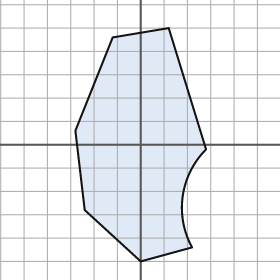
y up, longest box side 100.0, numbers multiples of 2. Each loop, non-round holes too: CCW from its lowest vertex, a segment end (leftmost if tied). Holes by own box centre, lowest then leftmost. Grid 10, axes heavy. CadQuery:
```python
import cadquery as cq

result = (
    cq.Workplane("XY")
    .moveTo(0.0, -50.0)
    .lineTo(22.0, -44.0)
    .threePointArc((18.0, -22.0), (28.0, -2.0))
    .lineTo(12.0, 50.0)
    .lineTo(-12.0, 46.0)
    .lineTo(-28.0, 6.0)
    .lineTo(-24.0, -28.0)
    .close()
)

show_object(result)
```